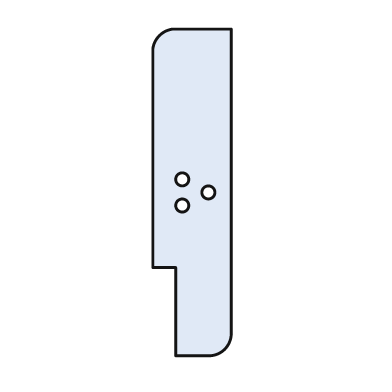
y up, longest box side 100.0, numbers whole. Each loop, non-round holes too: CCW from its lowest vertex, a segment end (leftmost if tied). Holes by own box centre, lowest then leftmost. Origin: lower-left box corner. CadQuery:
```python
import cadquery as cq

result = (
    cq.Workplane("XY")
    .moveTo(7.0, 0.0)
    .lineTo(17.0, 0.0)
    .threePointArc((22.0, 2.0), (24.0, 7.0))
    .lineTo(24.0, 100.0)
    .lineTo(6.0, 100.0)
    .threePointArc((2.0, 98.0), (0.0, 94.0))
    .lineTo(0.0, 27.0)
    .lineTo(7.0, 27.0)
    .close()
    .moveTo(9.0, 46.0)
    .circle(2.0)
    .moveTo(17.0, 50.0)
    .circle(2.0)
    .moveTo(9.0, 54.0)
    .circle(2.0)
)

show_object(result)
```